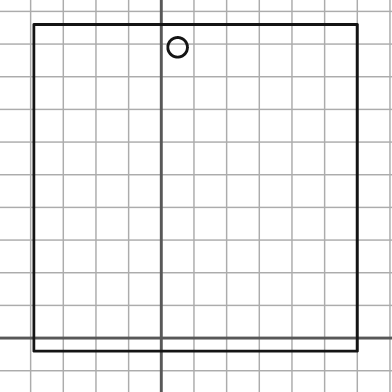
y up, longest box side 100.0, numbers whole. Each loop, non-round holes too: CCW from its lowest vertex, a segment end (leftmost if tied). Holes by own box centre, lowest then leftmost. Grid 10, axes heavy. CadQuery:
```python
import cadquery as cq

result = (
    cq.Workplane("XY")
    .moveTo(-39.0, -4.0)
    .lineTo(60.0, -4.0)
    .lineTo(60.0, 96.0)
    .lineTo(-39.0, 96.0)
    .close()
    .moveTo(5.0, 89.0)
    .circle(3.0)
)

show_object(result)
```